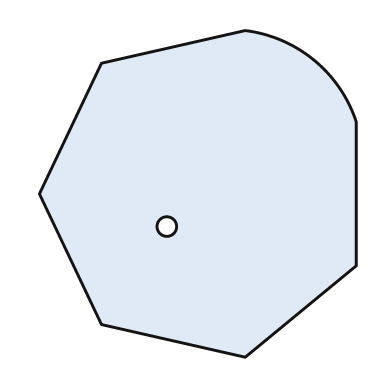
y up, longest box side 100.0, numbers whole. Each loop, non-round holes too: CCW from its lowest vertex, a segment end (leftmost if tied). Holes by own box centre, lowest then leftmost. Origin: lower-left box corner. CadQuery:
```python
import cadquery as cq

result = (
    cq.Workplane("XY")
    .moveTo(63.0, 0.0)
    .lineTo(97.0, 28.0)
    .lineTo(97.0, 72.0)
    .threePointArc((84.0, 91.0), (63.0, 100.0))
    .lineTo(19.0, 90.0)
    .lineTo(0.0, 50.0)
    .lineTo(19.0, 10.0)
    .close()
    .moveTo(39.0, 40.0)
    .circle(3.0)
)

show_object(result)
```